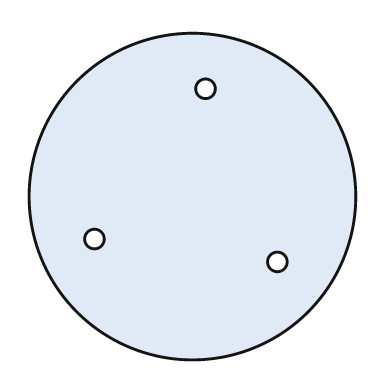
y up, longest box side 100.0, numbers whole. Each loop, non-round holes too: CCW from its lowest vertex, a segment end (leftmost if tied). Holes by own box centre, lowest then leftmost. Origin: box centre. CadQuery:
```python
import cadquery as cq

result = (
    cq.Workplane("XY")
    .moveTo(0.0, 0.0)
    .circle(50.0)
    .moveTo(26.0, -20.0)
    .circle(3.0)
    .moveTo(-30.0, -13.0)
    .circle(3.0)
    .moveTo(4.0, 33.0)
    .circle(3.0)
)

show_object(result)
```